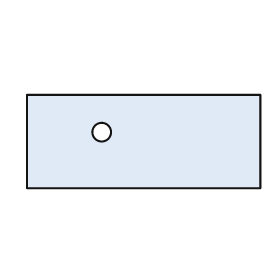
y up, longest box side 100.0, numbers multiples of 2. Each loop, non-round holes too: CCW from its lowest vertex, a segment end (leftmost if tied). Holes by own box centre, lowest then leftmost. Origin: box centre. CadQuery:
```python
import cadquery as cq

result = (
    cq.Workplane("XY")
    .moveTo(-50.0, -20.0)
    .lineTo(50.0, -20.0)
    .lineTo(50.0, 20.0)
    .lineTo(-50.0, 20.0)
    .close()
    .moveTo(-18.0, 4.0)
    .circle(4.0)
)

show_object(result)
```